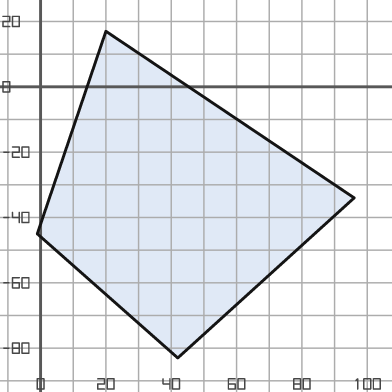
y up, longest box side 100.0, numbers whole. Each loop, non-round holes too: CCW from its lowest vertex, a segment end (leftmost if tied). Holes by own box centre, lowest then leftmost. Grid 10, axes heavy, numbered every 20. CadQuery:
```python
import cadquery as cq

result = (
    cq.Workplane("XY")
    .moveTo(42.0, -83.0)
    .lineTo(96.0, -34.0)
    .lineTo(20.0, 17.0)
    .lineTo(-1.0, -45.0)
    .close()
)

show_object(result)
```